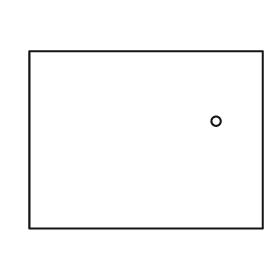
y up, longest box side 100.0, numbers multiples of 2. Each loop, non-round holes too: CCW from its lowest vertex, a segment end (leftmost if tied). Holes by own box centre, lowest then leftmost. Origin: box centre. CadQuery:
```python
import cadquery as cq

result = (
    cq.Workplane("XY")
    .moveTo(-50.0, -38.0)
    .lineTo(50.0, -38.0)
    .lineTo(50.0, 38.0)
    .lineTo(-50.0, 38.0)
    .close()
    .moveTo(30.0, 8.0)
    .circle(2.0)
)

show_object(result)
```